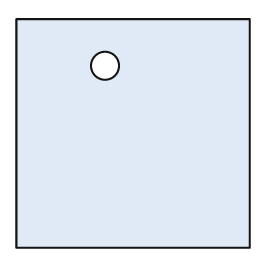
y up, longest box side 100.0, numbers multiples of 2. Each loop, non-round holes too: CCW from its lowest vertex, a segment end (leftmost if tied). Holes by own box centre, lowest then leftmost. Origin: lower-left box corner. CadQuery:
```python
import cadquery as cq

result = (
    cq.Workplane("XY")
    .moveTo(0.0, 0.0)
    .lineTo(100.0, 0.0)
    .lineTo(100.0, 98.0)
    .lineTo(0.0, 98.0)
    .close()
    .moveTo(38.0, 78.0)
    .circle(6.0)
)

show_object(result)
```